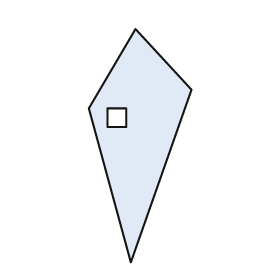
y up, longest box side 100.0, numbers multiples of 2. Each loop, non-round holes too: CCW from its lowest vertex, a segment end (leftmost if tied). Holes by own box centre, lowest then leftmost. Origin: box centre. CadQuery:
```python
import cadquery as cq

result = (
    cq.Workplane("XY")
    .moveTo(-4.0, -50.0)
    .lineTo(22.0, 24.0)
    .lineTo(-2.0, 50.0)
    .lineTo(-22.0, 16.0)
    .close()
    .moveTo(-14.0, 8.0)
    .lineTo(-6.0, 8.0)
    .lineTo(-6.0, 16.0)
    .lineTo(-14.0, 16.0)
    .close()
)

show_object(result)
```